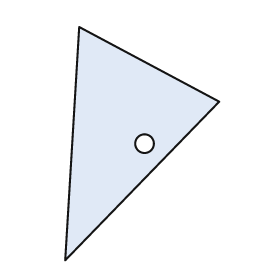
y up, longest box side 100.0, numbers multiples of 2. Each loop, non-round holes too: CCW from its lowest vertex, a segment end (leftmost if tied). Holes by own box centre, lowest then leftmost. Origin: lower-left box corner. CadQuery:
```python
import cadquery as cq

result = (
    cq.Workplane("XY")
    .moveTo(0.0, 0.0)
    .lineTo(66.0, 68.0)
    .lineTo(6.0, 100.0)
    .close()
    .moveTo(34.0, 50.0)
    .circle(4.0)
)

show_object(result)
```